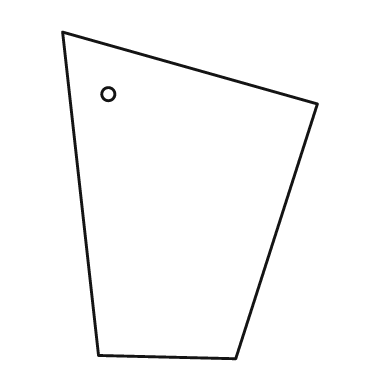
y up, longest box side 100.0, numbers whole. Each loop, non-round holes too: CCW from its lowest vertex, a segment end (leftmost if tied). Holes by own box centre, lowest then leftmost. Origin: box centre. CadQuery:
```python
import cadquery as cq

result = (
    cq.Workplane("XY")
    .moveTo(14.0, -50.0)
    .lineTo(39.0, 28.0)
    .lineTo(-39.0, 50.0)
    .lineTo(-28.0, -49.0)
    .close()
    .moveTo(-25.0, 31.0)
    .circle(2.0)
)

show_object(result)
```